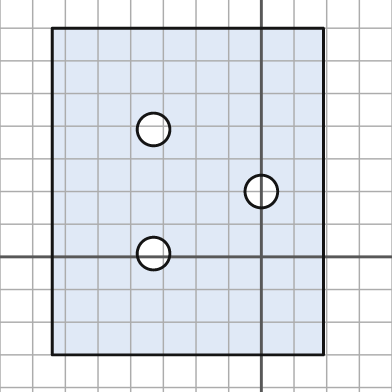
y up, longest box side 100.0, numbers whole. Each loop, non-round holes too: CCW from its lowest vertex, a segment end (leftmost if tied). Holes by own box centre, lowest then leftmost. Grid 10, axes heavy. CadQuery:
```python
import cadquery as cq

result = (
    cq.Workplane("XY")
    .moveTo(-64.0, -30.0)
    .lineTo(19.0, -30.0)
    .lineTo(19.0, 70.0)
    .lineTo(-64.0, 70.0)
    .close()
    .moveTo(-33.0, 1.0)
    .circle(5.0)
    .moveTo(0.0, 20.0)
    .circle(5.0)
    .moveTo(-33.0, 39.0)
    .circle(5.0)
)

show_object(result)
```